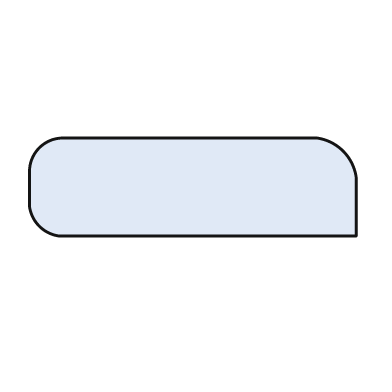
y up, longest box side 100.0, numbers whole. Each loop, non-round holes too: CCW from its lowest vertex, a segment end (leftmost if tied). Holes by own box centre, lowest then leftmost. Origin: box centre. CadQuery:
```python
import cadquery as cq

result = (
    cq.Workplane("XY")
    .moveTo(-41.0, -15.0)
    .lineTo(50.0, -15.0)
    .lineTo(50.0, 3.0)
    .threePointArc((46.0, 11.0), (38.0, 15.0))
    .lineTo(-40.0, 15.0)
    .threePointArc((-47.0, 12.0), (-50.0, 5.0))
    .lineTo(-50.0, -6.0)
    .threePointArc((-47.0, -12.0), (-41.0, -15.0))
    .close()
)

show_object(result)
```